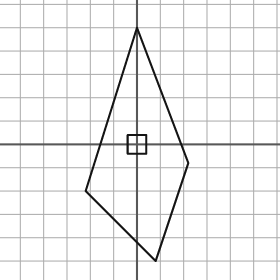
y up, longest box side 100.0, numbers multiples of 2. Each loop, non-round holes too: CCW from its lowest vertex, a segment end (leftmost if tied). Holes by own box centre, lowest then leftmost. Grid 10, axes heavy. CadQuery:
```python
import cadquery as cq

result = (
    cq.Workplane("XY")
    .moveTo(8.0, -50.0)
    .lineTo(22.0, -8.0)
    .lineTo(0.0, 50.0)
    .lineTo(-22.0, -20.0)
    .close()
    .moveTo(-4.0, -4.0)
    .lineTo(4.0, -4.0)
    .lineTo(4.0, 4.0)
    .lineTo(-4.0, 4.0)
    .close()
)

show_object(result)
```